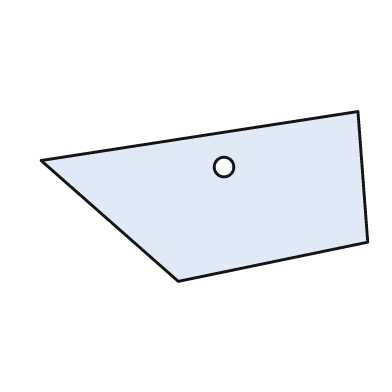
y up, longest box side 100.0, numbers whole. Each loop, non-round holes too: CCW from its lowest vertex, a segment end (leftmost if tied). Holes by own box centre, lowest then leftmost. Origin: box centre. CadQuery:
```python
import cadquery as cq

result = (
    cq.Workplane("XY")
    .moveTo(-8.0, -26.0)
    .lineTo(50.0, -14.0)
    .lineTo(47.0, 26.0)
    .lineTo(-50.0, 11.0)
    .close()
    .moveTo(6.0, 9.0)
    .circle(3.0)
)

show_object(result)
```